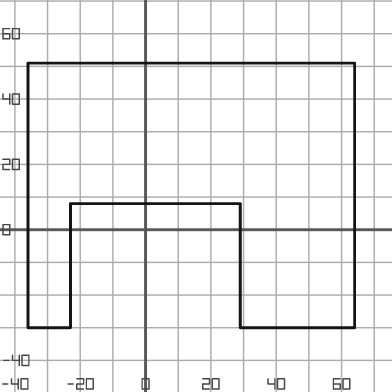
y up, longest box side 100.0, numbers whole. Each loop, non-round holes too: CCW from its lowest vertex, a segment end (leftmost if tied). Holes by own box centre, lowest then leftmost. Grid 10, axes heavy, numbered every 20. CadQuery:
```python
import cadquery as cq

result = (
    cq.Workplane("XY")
    .moveTo(-36.0, -30.0)
    .lineTo(-23.0, -30.0)
    .lineTo(-23.0, 8.0)
    .lineTo(29.0, 8.0)
    .lineTo(29.0, -30.0)
    .lineTo(64.0, -30.0)
    .lineTo(64.0, 51.0)
    .lineTo(-36.0, 51.0)
    .close()
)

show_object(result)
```